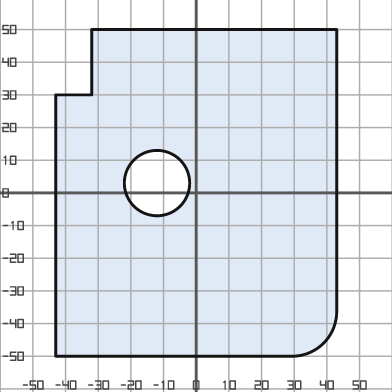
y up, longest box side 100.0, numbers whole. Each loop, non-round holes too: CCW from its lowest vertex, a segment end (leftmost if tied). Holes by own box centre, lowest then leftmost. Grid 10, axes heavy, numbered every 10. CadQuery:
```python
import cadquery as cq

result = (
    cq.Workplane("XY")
    .moveTo(-43.0, -50.0)
    .lineTo(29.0, -50.0)
    .threePointArc((39.0, -46.0), (43.0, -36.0))
    .lineTo(43.0, 50.0)
    .lineTo(-32.0, 50.0)
    .lineTo(-32.0, 30.0)
    .lineTo(-43.0, 30.0)
    .close()
    .moveTo(-12.0, 3.0)
    .circle(10.0)
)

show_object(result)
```